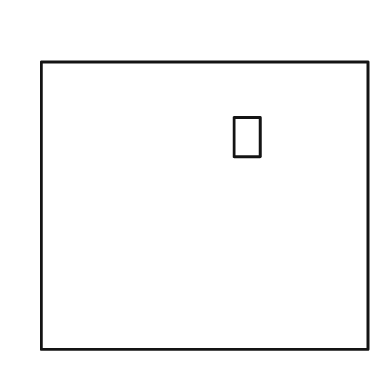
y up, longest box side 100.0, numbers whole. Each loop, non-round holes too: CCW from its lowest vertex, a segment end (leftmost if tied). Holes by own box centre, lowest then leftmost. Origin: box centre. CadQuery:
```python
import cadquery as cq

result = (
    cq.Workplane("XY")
    .moveTo(-50.0, -44.0)
    .lineTo(50.0, -44.0)
    .lineTo(50.0, 44.0)
    .lineTo(-50.0, 44.0)
    .close()
    .moveTo(9.0, 15.0)
    .lineTo(17.0, 15.0)
    .lineTo(17.0, 27.0)
    .lineTo(9.0, 27.0)
    .close()
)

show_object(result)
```